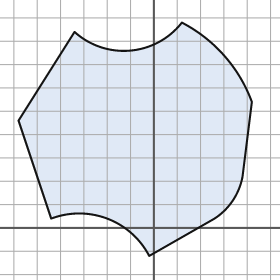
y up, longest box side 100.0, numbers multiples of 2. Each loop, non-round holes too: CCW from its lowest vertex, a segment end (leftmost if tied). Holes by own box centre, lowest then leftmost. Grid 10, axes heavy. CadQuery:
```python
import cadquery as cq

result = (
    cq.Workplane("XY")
    .moveTo(-2.0, -12.0)
    .lineTo(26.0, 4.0)
    .threePointArc((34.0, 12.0), (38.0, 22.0))
    .lineTo(42.0, 54.0)
    .threePointArc((30.0, 74.0), (12.0, 88.0))
    .threePointArc((-10.0, 76.0), (-34.0, 84.0))
    .lineTo(-58.0, 46.0)
    .lineTo(-44.0, 4.0)
    .threePointArc((-20.0, 4.0), (-2.0, -12.0))
    .close()
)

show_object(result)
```